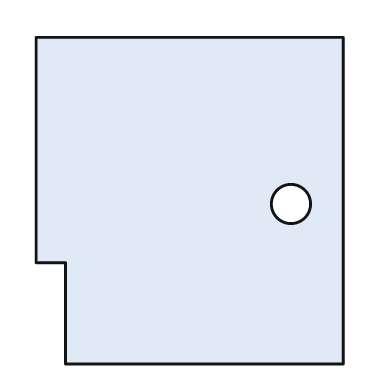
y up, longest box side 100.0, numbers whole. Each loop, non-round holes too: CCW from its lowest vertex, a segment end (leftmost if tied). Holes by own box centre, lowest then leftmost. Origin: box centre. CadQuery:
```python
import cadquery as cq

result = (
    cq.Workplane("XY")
    .moveTo(-38.0, -50.0)
    .lineTo(47.0, -50.0)
    .lineTo(47.0, 50.0)
    .lineTo(-47.0, 50.0)
    .lineTo(-47.0, -19.0)
    .lineTo(-38.0, -19.0)
    .close()
    .moveTo(31.0, -1.0)
    .circle(6.0)
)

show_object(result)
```